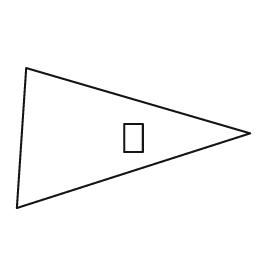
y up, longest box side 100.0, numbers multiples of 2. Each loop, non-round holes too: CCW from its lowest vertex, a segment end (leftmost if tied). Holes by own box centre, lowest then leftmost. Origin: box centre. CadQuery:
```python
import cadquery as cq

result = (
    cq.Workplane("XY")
    .moveTo(-50.0, -30.0)
    .lineTo(50.0, 2.0)
    .lineTo(-46.0, 30.0)
    .close()
    .moveTo(-4.0, -6.0)
    .lineTo(4.0, -6.0)
    .lineTo(4.0, 6.0)
    .lineTo(-4.0, 6.0)
    .close()
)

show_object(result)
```